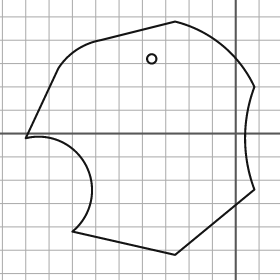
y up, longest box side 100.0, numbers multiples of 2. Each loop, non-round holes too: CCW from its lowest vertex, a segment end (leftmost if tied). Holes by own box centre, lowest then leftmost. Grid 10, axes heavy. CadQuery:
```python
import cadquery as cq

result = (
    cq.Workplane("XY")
    .moveTo(-26.0, -52.0)
    .lineTo(8.0, -24.0)
    .threePointArc((4.0, -2.0), (8.0, 20.0))
    .threePointArc((-6.0, 38.0), (-26.0, 48.0))
    .lineTo(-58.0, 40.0)
    .threePointArc((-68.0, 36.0), (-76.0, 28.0))
    .lineTo(-90.0, -2.0)
    .threePointArc((-64.0, -14.0), (-70.0, -42.0))
    .close()
    .moveTo(-36.0, 32.0)
    .circle(2.0)
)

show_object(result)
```